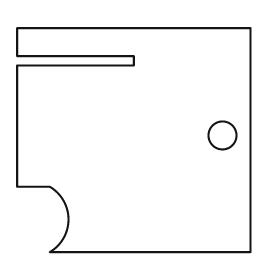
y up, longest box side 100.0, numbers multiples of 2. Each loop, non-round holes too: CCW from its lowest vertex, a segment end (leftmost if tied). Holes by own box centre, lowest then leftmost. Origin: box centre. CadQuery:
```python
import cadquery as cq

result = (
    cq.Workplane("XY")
    .moveTo(-36.0, -48.0)
    .lineTo(50.0, -48.0)
    .lineTo(50.0, 48.0)
    .lineTo(-50.0, 48.0)
    .lineTo(-50.0, 36.0)
    .lineTo(0.0, 36.0)
    .lineTo(0.0, 32.0)
    .lineTo(-50.0, 32.0)
    .lineTo(-50.0, -20.0)
    .lineTo(-36.0, -20.0)
    .threePointArc((-28.0, -34.0), (-36.0, -48.0))
    .close()
    .moveTo(38.0, 2.0)
    .circle(6.0)
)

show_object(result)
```